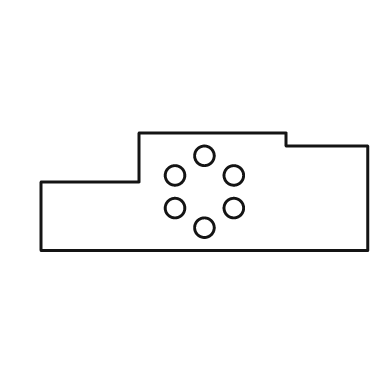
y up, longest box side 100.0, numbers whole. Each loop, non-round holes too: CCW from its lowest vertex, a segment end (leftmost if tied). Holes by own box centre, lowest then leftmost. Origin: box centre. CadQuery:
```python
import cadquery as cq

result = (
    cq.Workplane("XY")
    .moveTo(-50.0, -18.0)
    .lineTo(50.0, -18.0)
    .lineTo(50.0, 14.0)
    .lineTo(25.0, 14.0)
    .lineTo(25.0, 18.0)
    .lineTo(-20.0, 18.0)
    .lineTo(-20.0, 3.0)
    .lineTo(-50.0, 3.0)
    .close()
    .moveTo(0.0, -11.0)
    .circle(3.0)
    .moveTo(-9.0, -5.0)
    .circle(3.0)
    .moveTo(9.0, -5.0)
    .circle(3.0)
    .moveTo(-9.0, 5.0)
    .circle(3.0)
    .moveTo(9.0, 5.0)
    .circle(3.0)
    .moveTo(0.0, 11.0)
    .circle(3.0)
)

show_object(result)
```